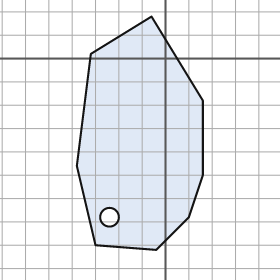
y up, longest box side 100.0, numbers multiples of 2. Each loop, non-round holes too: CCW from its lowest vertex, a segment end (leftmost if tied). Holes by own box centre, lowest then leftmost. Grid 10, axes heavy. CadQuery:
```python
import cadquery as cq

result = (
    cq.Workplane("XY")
    .moveTo(-4.0, -82.0)
    .lineTo(10.0, -68.0)
    .lineTo(16.0, -50.0)
    .lineTo(16.0, -18.0)
    .lineTo(-6.0, 18.0)
    .lineTo(-32.0, 2.0)
    .lineTo(-38.0, -46.0)
    .lineTo(-30.0, -80.0)
    .close()
    .moveTo(-24.0, -68.0)
    .circle(4.0)
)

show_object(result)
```